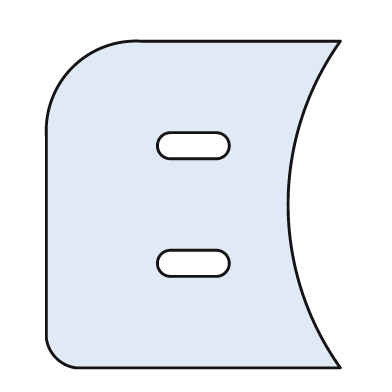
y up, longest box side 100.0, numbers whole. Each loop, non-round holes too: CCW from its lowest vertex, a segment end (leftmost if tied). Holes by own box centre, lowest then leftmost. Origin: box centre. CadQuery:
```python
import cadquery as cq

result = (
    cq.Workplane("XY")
    .moveTo(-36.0, -50.0)
    .lineTo(45.0, -50.0)
    .threePointArc((29.0, 0.0), (45.0, 50.0))
    .lineTo(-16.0, 50.0)
    .threePointArc((-37.0, 42.0), (-45.0, 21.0))
    .lineTo(-45.0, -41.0)
    .threePointArc((-42.0, -47.0), (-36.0, -50.0))
    .close()
    .moveTo(-7.0, -22.0)
    .lineTo(7.0, -22.0)
    .threePointArc((11.0, -18.0), (7.0, -14.0))
    .lineTo(-7.0, -14.0)
    .threePointArc((-11.0, -18.0), (-7.0, -22.0))
    .close()
    .moveTo(-7.0, 14.0)
    .lineTo(7.0, 14.0)
    .threePointArc((11.0, 18.0), (7.0, 22.0))
    .lineTo(-7.0, 22.0)
    .threePointArc((-11.0, 18.0), (-7.0, 14.0))
    .close()
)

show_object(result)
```